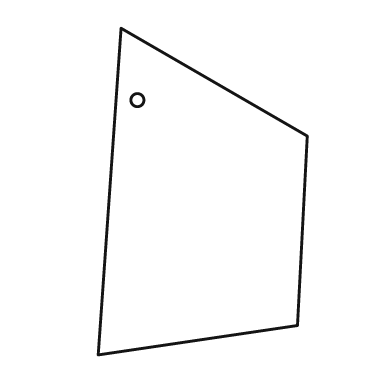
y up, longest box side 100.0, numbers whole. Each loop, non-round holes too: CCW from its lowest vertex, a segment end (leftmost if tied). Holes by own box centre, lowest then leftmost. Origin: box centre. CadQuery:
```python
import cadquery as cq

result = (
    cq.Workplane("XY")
    .moveTo(-32.0, -50.0)
    .lineTo(29.0, -41.0)
    .lineTo(32.0, 17.0)
    .lineTo(-25.0, 50.0)
    .close()
    .moveTo(-20.0, 28.0)
    .circle(2.0)
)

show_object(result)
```